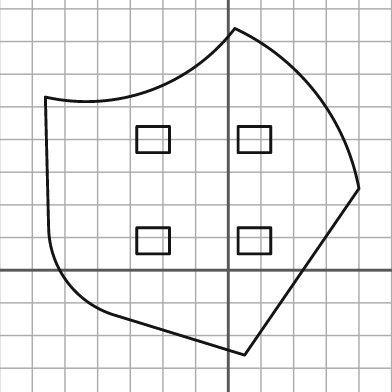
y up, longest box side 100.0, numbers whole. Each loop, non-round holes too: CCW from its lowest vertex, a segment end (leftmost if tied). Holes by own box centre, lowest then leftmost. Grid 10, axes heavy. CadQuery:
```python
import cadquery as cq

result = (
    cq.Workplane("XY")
    .moveTo(5.0, -26.0)
    .lineTo(40.0, 25.0)
    .threePointArc((27.0, 54.0), (2.0, 74.0))
    .threePointArc((-24.0, 55.0), (-56.0, 53.0))
    .lineTo(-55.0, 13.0)
    .threePointArc((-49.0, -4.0), (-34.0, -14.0))
    .close()
    .moveTo(-28.0, 5.0)
    .lineTo(-18.0, 5.0)
    .lineTo(-18.0, 13.0)
    .lineTo(-28.0, 13.0)
    .close()
    .moveTo(3.0, 5.0)
    .lineTo(13.0, 5.0)
    .lineTo(13.0, 13.0)
    .lineTo(3.0, 13.0)
    .close()
    .moveTo(-28.0, 36.0)
    .lineTo(-18.0, 36.0)
    .lineTo(-18.0, 44.0)
    .lineTo(-28.0, 44.0)
    .close()
    .moveTo(3.0, 36.0)
    .lineTo(13.0, 36.0)
    .lineTo(13.0, 44.0)
    .lineTo(3.0, 44.0)
    .close()
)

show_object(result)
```